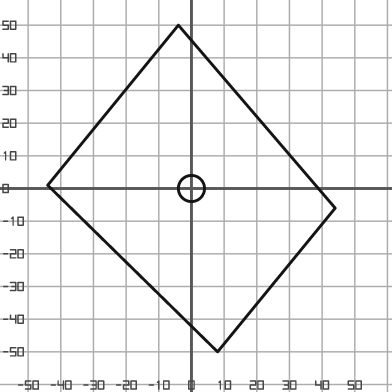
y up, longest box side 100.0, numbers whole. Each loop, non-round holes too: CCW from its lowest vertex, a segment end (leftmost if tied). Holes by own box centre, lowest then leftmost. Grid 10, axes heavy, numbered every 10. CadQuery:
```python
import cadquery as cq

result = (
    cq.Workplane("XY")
    .moveTo(8.0, -50.0)
    .lineTo(44.0, -6.0)
    .lineTo(-4.0, 50.0)
    .lineTo(-44.0, 1.0)
    .close()
    .moveTo(0.0, 0.0)
    .circle(4.0)
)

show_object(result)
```